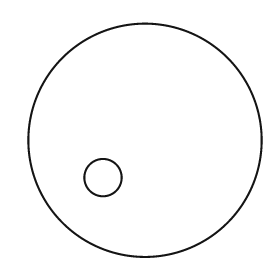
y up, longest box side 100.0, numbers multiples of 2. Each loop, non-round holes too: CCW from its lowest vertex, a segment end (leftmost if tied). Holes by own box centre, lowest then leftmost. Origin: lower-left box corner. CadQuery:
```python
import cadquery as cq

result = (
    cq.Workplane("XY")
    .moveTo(50.0, 50.0)
    .circle(50.0)
    .moveTo(32.0, 34.0)
    .circle(8.0)
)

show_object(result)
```